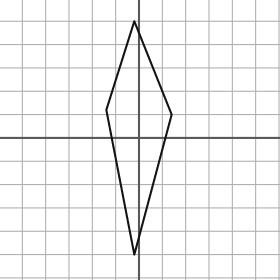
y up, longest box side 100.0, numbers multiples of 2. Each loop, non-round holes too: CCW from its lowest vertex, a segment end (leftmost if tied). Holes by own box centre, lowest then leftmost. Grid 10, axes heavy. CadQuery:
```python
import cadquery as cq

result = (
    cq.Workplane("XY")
    .moveTo(-2.0, -50.0)
    .lineTo(14.0, 10.0)
    .lineTo(-2.0, 50.0)
    .lineTo(-14.0, 12.0)
    .close()
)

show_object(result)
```